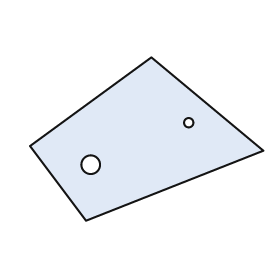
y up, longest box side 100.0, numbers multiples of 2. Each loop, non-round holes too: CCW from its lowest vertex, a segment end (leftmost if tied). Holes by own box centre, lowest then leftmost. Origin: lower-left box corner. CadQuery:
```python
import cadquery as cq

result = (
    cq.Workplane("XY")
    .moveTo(24.0, 0.0)
    .lineTo(100.0, 30.0)
    .lineTo(52.0, 70.0)
    .lineTo(0.0, 32.0)
    .close()
    .moveTo(26.0, 24.0)
    .circle(4.0)
    .moveTo(68.0, 42.0)
    .circle(2.0)
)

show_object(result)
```